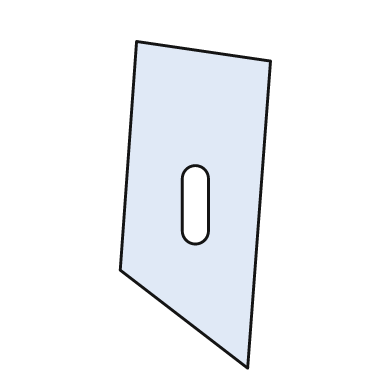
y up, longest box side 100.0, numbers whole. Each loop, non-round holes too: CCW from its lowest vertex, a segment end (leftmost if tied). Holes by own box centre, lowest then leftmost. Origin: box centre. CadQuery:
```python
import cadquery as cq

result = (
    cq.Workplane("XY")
    .moveTo(16.0, -50.0)
    .lineTo(23.0, 44.0)
    .lineTo(-18.0, 50.0)
    .lineTo(-23.0, -20.0)
    .close()
    .moveTo(-4.0, -8.0)
    .threePointArc((0.0, -12.0), (4.0, -8.0))
    .lineTo(4.0, 8.0)
    .threePointArc((0.0, 12.0), (-4.0, 8.0))
    .close()
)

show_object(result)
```